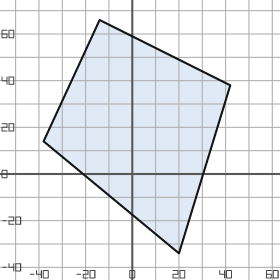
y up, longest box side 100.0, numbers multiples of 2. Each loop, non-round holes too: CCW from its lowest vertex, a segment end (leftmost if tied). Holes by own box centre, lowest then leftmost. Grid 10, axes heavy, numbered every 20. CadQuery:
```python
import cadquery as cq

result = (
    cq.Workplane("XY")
    .moveTo(20.0, -34.0)
    .lineTo(42.0, 38.0)
    .lineTo(-14.0, 66.0)
    .lineTo(-38.0, 14.0)
    .close()
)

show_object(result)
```